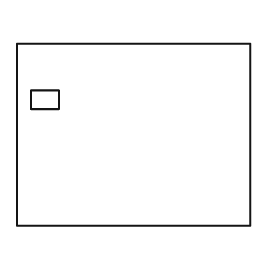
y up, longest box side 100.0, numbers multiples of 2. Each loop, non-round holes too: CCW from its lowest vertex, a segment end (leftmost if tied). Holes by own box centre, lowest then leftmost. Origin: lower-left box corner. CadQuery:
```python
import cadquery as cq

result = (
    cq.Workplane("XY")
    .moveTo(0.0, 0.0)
    .lineTo(100.0, 0.0)
    .lineTo(100.0, 78.0)
    .lineTo(0.0, 78.0)
    .close()
    .moveTo(6.0, 50.0)
    .lineTo(18.0, 50.0)
    .lineTo(18.0, 58.0)
    .lineTo(6.0, 58.0)
    .close()
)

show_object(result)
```